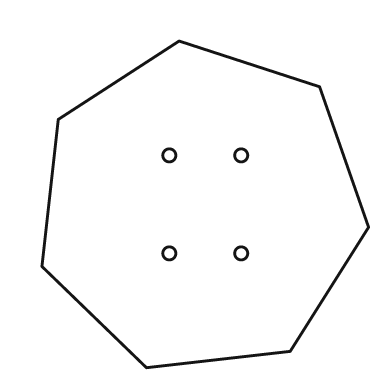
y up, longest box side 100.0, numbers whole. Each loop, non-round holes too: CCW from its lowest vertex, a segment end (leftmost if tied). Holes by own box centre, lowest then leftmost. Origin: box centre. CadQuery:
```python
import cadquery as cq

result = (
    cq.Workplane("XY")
    .moveTo(-18.0, -50.0)
    .lineTo(26.0, -45.0)
    .lineTo(50.0, -7.0)
    .lineTo(35.0, 36.0)
    .lineTo(-8.0, 50.0)
    .lineTo(-45.0, 26.0)
    .lineTo(-50.0, -19.0)
    .close()
    .moveTo(-11.0, -15.0)
    .circle(2.0)
    .moveTo(11.0, -15.0)
    .circle(2.0)
    .moveTo(-11.0, 15.0)
    .circle(2.0)
    .moveTo(11.0, 15.0)
    .circle(2.0)
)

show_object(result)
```